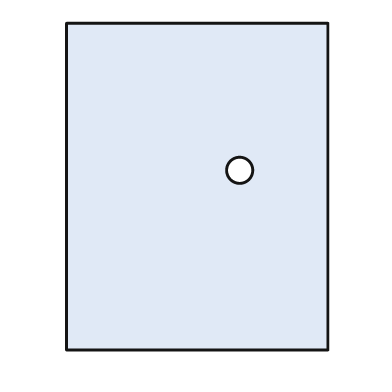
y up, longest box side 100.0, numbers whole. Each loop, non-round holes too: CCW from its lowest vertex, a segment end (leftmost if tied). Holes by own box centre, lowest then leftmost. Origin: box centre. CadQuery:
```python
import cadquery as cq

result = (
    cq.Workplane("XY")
    .moveTo(-40.0, -50.0)
    .lineTo(40.0, -50.0)
    .lineTo(40.0, 50.0)
    .lineTo(-40.0, 50.0)
    .close()
    .moveTo(13.0, 5.0)
    .circle(4.0)
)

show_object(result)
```